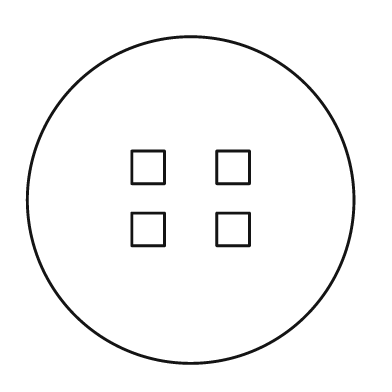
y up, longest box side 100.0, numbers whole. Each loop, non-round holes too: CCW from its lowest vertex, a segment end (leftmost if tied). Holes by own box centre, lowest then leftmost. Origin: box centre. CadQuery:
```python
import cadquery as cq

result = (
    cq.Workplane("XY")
    .moveTo(0.0, 0.0)
    .circle(50.0)
    .moveTo(-18.0, -14.0)
    .lineTo(-8.0, -14.0)
    .lineTo(-8.0, -4.0)
    .lineTo(-18.0, -4.0)
    .close()
    .moveTo(8.0, -14.0)
    .lineTo(18.0, -14.0)
    .lineTo(18.0, -4.0)
    .lineTo(8.0, -4.0)
    .close()
    .moveTo(-18.0, 5.0)
    .lineTo(-8.0, 5.0)
    .lineTo(-8.0, 15.0)
    .lineTo(-18.0, 15.0)
    .close()
    .moveTo(8.0, 5.0)
    .lineTo(18.0, 5.0)
    .lineTo(18.0, 15.0)
    .lineTo(8.0, 15.0)
    .close()
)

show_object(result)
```